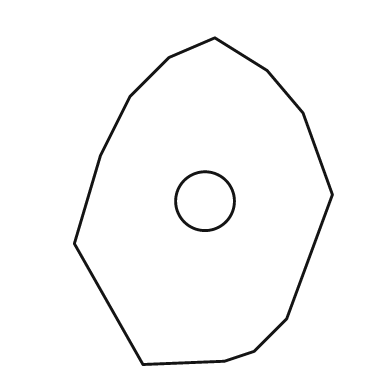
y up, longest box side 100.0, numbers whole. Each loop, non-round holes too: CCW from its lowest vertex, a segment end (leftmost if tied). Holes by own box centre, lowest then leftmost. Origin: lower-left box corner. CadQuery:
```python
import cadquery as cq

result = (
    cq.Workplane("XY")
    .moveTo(21.0, 0.0)
    .lineTo(46.0, 1.0)
    .lineTo(55.0, 4.0)
    .lineTo(65.0, 14.0)
    .lineTo(79.0, 52.0)
    .lineTo(70.0, 77.0)
    .lineTo(59.0, 90.0)
    .lineTo(43.0, 100.0)
    .lineTo(29.0, 94.0)
    .lineTo(17.0, 82.0)
    .lineTo(8.0, 64.0)
    .lineTo(0.0, 37.0)
    .close()
    .moveTo(40.0, 50.0)
    .circle(9.0)
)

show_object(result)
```